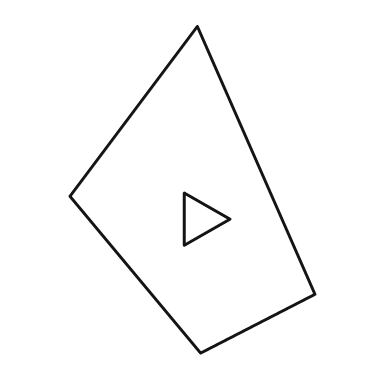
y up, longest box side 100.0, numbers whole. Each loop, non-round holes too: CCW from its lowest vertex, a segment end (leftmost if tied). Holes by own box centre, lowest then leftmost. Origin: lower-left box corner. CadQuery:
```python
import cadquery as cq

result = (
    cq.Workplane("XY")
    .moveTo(40.0, 0.0)
    .lineTo(75.0, 18.0)
    .lineTo(39.0, 100.0)
    .lineTo(0.0, 48.0)
    .close()
    .moveTo(35.0, 33.0)
    .lineTo(49.0, 41.0)
    .lineTo(35.0, 49.0)
    .close()
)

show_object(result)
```